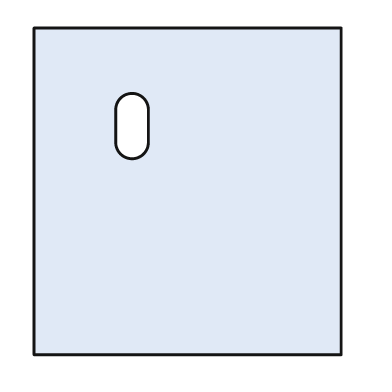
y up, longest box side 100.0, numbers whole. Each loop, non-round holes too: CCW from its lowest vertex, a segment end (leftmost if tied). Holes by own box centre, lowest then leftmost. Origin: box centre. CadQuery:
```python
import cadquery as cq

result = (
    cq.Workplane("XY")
    .moveTo(-47.0, -50.0)
    .lineTo(47.0, -50.0)
    .lineTo(47.0, 50.0)
    .lineTo(-47.0, 50.0)
    .close()
    .moveTo(-22.0, 15.0)
    .threePointArc((-17.0, 10.0), (-12.0, 15.0))
    .lineTo(-12.0, 25.0)
    .threePointArc((-17.0, 30.0), (-22.0, 25.0))
    .close()
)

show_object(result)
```